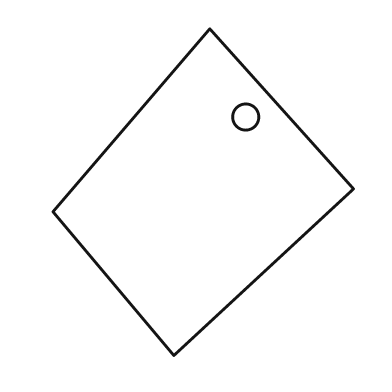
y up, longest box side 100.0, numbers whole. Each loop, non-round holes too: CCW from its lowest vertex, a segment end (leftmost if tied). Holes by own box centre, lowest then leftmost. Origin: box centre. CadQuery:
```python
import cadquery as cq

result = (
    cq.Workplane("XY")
    .moveTo(-9.0, -50.0)
    .lineTo(46.0, 1.0)
    .lineTo(2.0, 50.0)
    .lineTo(-46.0, -6.0)
    .close()
    .moveTo(13.0, 23.0)
    .circle(4.0)
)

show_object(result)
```